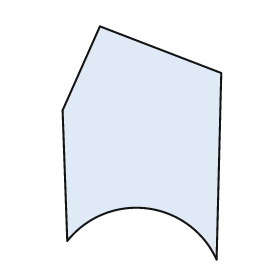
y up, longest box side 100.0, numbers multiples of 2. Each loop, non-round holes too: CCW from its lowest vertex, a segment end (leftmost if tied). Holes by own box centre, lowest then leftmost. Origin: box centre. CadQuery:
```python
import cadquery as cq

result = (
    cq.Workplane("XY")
    .moveTo(32.0, -50.0)
    .lineTo(34.0, 30.0)
    .lineTo(-18.0, 50.0)
    .lineTo(-34.0, 14.0)
    .lineTo(-32.0, -42.0)
    .threePointArc((2.0, -28.0), (32.0, -50.0))
    .close()
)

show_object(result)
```